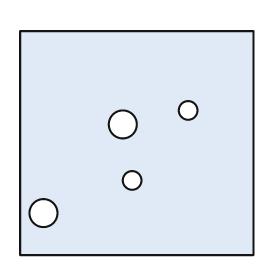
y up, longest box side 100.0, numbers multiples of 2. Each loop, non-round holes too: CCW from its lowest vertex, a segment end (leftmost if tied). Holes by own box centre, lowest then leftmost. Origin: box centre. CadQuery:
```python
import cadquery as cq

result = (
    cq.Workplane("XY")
    .moveTo(-50.0, -48.0)
    .lineTo(50.0, -48.0)
    .lineTo(50.0, 48.0)
    .lineTo(-50.0, 48.0)
    .close()
    .moveTo(-40.0, -30.0)
    .circle(6.0)
    .moveTo(-2.0, -16.0)
    .circle(4.0)
    .moveTo(-6.0, 8.0)
    .circle(6.0)
    .moveTo(22.0, 14.0)
    .circle(4.0)
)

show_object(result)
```